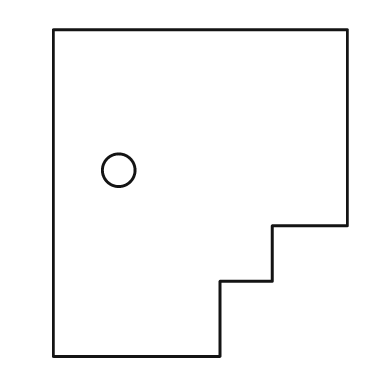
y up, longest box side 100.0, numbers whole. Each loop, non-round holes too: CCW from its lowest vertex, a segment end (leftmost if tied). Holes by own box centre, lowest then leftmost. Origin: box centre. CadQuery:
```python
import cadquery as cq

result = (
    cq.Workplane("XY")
    .moveTo(-45.0, -50.0)
    .lineTo(6.0, -50.0)
    .lineTo(6.0, -27.0)
    .lineTo(22.0, -27.0)
    .lineTo(22.0, -10.0)
    .lineTo(45.0, -10.0)
    .lineTo(45.0, 50.0)
    .lineTo(-45.0, 50.0)
    .close()
    .moveTo(-25.0, 7.0)
    .circle(5.0)
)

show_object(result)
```